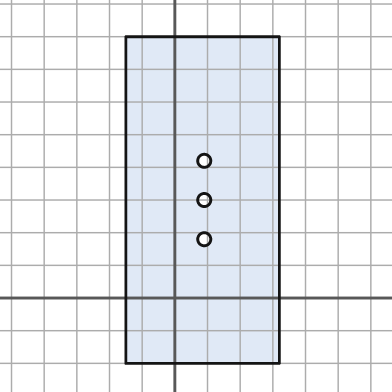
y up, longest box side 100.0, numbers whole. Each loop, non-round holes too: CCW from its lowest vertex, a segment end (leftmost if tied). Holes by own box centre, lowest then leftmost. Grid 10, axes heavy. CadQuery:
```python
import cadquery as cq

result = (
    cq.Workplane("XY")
    .moveTo(-15.0, -20.0)
    .lineTo(32.0, -20.0)
    .lineTo(32.0, 80.0)
    .lineTo(-15.0, 80.0)
    .close()
    .moveTo(9.0, 18.0)
    .circle(2.0)
    .moveTo(9.0, 30.0)
    .circle(2.0)
    .moveTo(9.0, 42.0)
    .circle(2.0)
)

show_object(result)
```